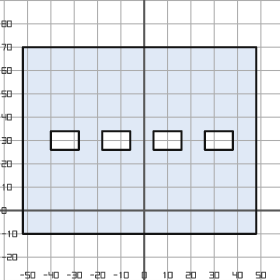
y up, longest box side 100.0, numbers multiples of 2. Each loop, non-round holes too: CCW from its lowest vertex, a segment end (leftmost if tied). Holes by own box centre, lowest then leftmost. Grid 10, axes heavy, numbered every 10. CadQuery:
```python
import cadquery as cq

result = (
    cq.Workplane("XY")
    .moveTo(-52.0, -10.0)
    .lineTo(48.0, -10.0)
    .lineTo(48.0, 70.0)
    .lineTo(-52.0, 70.0)
    .close()
    .moveTo(-40.0, 26.0)
    .lineTo(-28.0, 26.0)
    .lineTo(-28.0, 34.0)
    .lineTo(-40.0, 34.0)
    .close()
    .moveTo(-18.0, 26.0)
    .lineTo(-6.0, 26.0)
    .lineTo(-6.0, 34.0)
    .lineTo(-18.0, 34.0)
    .close()
    .moveTo(4.0, 26.0)
    .lineTo(16.0, 26.0)
    .lineTo(16.0, 34.0)
    .lineTo(4.0, 34.0)
    .close()
    .moveTo(26.0, 26.0)
    .lineTo(38.0, 26.0)
    .lineTo(38.0, 34.0)
    .lineTo(26.0, 34.0)
    .close()
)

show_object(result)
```